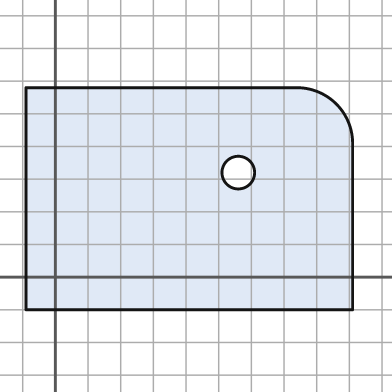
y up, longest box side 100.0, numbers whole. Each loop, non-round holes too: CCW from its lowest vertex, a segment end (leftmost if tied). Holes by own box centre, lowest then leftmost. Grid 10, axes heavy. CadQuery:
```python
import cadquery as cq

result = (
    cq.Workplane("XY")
    .moveTo(-9.0, -10.0)
    .lineTo(91.0, -10.0)
    .lineTo(91.0, 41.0)
    .threePointArc((86.0, 53.0), (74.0, 58.0))
    .lineTo(-9.0, 58.0)
    .close()
    .moveTo(56.0, 32.0)
    .circle(5.0)
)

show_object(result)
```